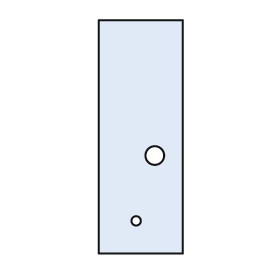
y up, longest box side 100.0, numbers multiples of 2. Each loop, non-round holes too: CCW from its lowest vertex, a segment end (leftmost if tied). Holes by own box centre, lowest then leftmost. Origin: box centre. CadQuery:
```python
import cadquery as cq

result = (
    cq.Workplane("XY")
    .moveTo(-18.0, -50.0)
    .lineTo(18.0, -50.0)
    .lineTo(18.0, 50.0)
    .lineTo(-18.0, 50.0)
    .close()
    .moveTo(-2.0, -36.0)
    .circle(2.0)
    .moveTo(6.0, -8.0)
    .circle(4.0)
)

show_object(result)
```